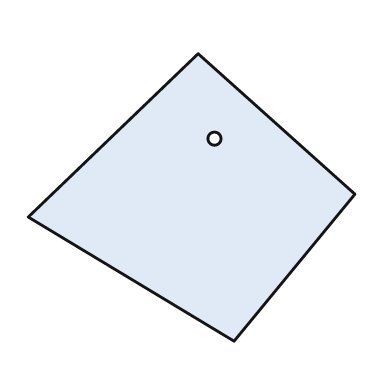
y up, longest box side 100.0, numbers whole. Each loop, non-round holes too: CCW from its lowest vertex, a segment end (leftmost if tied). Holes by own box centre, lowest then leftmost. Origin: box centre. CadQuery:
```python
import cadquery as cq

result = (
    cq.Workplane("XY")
    .moveTo(13.0, -44.0)
    .lineTo(50.0, 1.0)
    .lineTo(2.0, 44.0)
    .lineTo(-50.0, -6.0)
    .close()
    .moveTo(7.0, 18.0)
    .circle(2.0)
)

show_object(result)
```